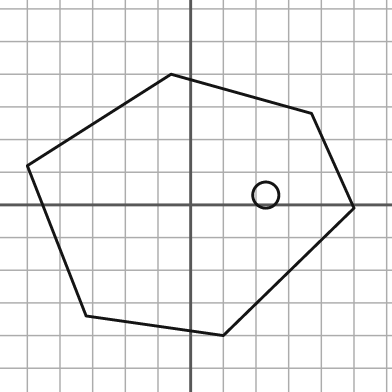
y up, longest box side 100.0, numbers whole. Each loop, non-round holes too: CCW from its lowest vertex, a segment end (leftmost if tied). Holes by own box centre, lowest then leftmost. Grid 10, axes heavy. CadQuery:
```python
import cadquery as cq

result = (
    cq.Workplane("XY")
    .moveTo(10.0, -40.0)
    .lineTo(50.0, -1.0)
    .lineTo(37.0, 28.0)
    .lineTo(-6.0, 40.0)
    .lineTo(-50.0, 12.0)
    .lineTo(-32.0, -34.0)
    .close()
    .moveTo(23.0, 3.0)
    .circle(4.0)
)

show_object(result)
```